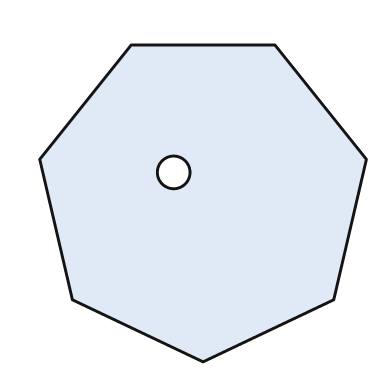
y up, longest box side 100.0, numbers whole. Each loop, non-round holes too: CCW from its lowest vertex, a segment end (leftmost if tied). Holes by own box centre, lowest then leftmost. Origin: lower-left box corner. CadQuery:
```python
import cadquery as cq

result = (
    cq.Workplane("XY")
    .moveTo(50.0, 0.0)
    .lineTo(90.0, 19.0)
    .lineTo(100.0, 62.0)
    .lineTo(72.0, 97.0)
    .lineTo(28.0, 97.0)
    .lineTo(0.0, 62.0)
    .lineTo(10.0, 19.0)
    .close()
    .moveTo(41.0, 58.0)
    .circle(5.0)
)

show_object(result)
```